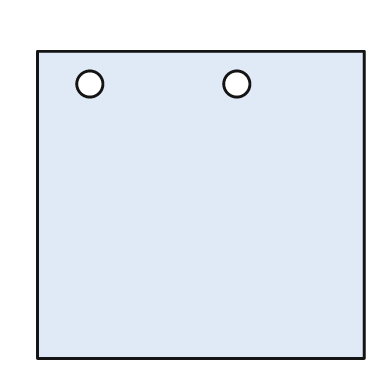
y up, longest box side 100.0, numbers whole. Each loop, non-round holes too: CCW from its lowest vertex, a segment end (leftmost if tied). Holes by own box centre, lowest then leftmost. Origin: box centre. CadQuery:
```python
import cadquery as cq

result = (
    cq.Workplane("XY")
    .moveTo(-50.0, -47.0)
    .lineTo(50.0, -47.0)
    .lineTo(50.0, 47.0)
    .lineTo(-50.0, 47.0)
    .close()
    .moveTo(-34.0, 37.0)
    .circle(4.0)
    .moveTo(11.0, 37.0)
    .circle(4.0)
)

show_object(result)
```